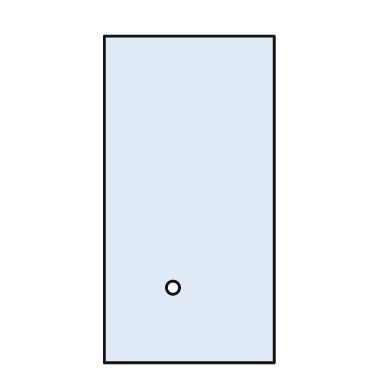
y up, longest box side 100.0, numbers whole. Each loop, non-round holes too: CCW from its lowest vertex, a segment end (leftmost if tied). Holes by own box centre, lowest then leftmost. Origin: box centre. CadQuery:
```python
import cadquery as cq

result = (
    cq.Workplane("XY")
    .moveTo(-26.0, -50.0)
    .lineTo(26.0, -50.0)
    .lineTo(26.0, 50.0)
    .lineTo(-26.0, 50.0)
    .close()
    .moveTo(-5.0, -27.0)
    .circle(2.0)
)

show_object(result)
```